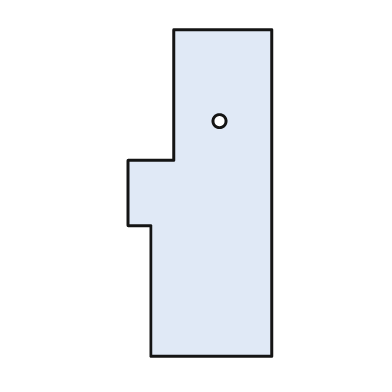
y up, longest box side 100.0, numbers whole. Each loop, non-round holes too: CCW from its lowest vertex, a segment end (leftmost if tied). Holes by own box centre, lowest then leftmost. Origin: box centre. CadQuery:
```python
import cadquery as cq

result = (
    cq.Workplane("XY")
    .moveTo(-15.0, -50.0)
    .lineTo(22.0, -50.0)
    .lineTo(22.0, 50.0)
    .lineTo(-8.0, 50.0)
    .lineTo(-8.0, 10.0)
    .lineTo(-22.0, 10.0)
    .lineTo(-22.0, -10.0)
    .lineTo(-15.0, -10.0)
    .close()
    .moveTo(6.0, 22.0)
    .circle(2.0)
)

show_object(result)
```